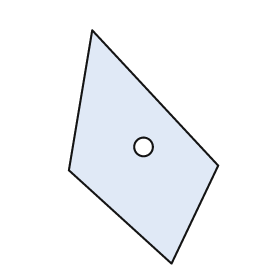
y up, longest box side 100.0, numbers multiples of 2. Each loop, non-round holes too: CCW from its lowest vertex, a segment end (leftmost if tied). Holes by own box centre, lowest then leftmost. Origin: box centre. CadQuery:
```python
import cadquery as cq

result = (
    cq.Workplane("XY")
    .moveTo(12.0, -50.0)
    .lineTo(32.0, -8.0)
    .lineTo(-22.0, 50.0)
    .lineTo(-32.0, -10.0)
    .close()
    .moveTo(0.0, 0.0)
    .circle(4.0)
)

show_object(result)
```